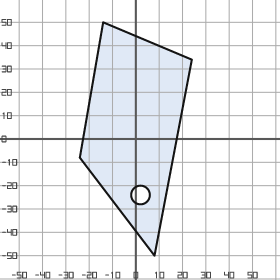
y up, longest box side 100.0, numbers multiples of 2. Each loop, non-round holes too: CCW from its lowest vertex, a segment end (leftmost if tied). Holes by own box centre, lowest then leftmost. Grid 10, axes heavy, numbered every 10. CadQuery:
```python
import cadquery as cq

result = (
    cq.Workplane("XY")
    .moveTo(8.0, -50.0)
    .lineTo(24.0, 34.0)
    .lineTo(-14.0, 50.0)
    .lineTo(-24.0, -8.0)
    .close()
    .moveTo(2.0, -24.0)
    .circle(4.0)
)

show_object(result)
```